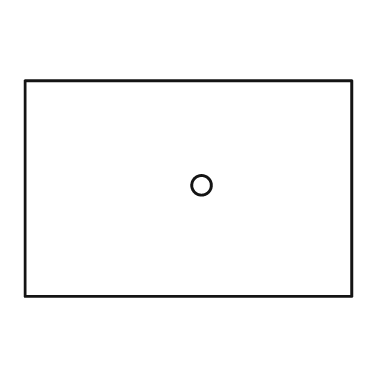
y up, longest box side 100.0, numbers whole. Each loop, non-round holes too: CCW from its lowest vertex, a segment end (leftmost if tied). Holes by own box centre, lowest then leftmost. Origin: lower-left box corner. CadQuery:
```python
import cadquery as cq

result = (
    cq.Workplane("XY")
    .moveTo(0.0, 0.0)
    .lineTo(100.0, 0.0)
    .lineTo(100.0, 66.0)
    .lineTo(0.0, 66.0)
    .close()
    .moveTo(54.0, 34.0)
    .circle(3.0)
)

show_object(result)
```